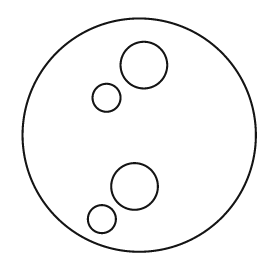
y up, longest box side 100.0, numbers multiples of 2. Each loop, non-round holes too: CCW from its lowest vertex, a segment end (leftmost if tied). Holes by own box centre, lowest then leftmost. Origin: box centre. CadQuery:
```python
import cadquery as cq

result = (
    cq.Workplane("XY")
    .moveTo(0.0, 0.0)
    .circle(50.0)
    .moveTo(-16.0, -36.0)
    .circle(6.0)
    .moveTo(-2.0, -22.0)
    .circle(10.0)
    .moveTo(-14.0, 16.0)
    .circle(6.0)
    .moveTo(2.0, 30.0)
    .circle(10.0)
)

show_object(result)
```